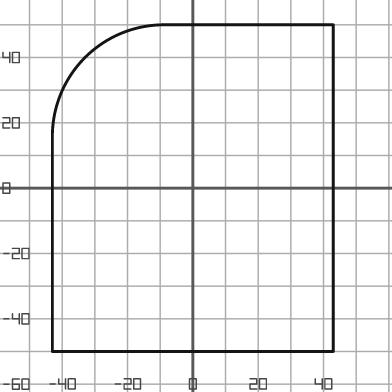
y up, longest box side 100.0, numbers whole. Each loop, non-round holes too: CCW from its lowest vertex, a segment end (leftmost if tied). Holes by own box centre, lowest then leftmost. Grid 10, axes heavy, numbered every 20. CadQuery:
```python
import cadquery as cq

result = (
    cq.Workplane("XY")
    .moveTo(-43.0, -50.0)
    .lineTo(43.0, -50.0)
    .lineTo(43.0, 50.0)
    .lineTo(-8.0, 50.0)
    .threePointArc((-33.0, 40.0), (-43.0, 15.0))
    .close()
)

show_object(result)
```